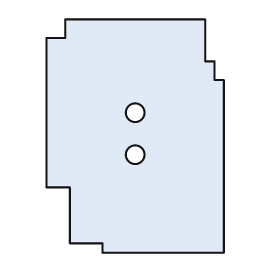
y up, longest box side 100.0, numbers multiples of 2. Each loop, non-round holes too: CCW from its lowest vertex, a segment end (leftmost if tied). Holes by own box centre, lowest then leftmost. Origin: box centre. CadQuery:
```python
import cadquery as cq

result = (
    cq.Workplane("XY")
    .moveTo(-14.0, -50.0)
    .lineTo(38.0, -50.0)
    .lineTo(38.0, 24.0)
    .lineTo(34.0, 24.0)
    .lineTo(34.0, 32.0)
    .lineTo(30.0, 32.0)
    .lineTo(30.0, 50.0)
    .lineTo(-30.0, 50.0)
    .lineTo(-30.0, 42.0)
    .lineTo(-38.0, 42.0)
    .lineTo(-38.0, -22.0)
    .lineTo(-28.0, -22.0)
    .lineTo(-28.0, -46.0)
    .lineTo(-14.0, -46.0)
    .close()
    .moveTo(0.0, -8.0)
    .circle(4.0)
    .moveTo(0.0, 10.0)
    .circle(4.0)
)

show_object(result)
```